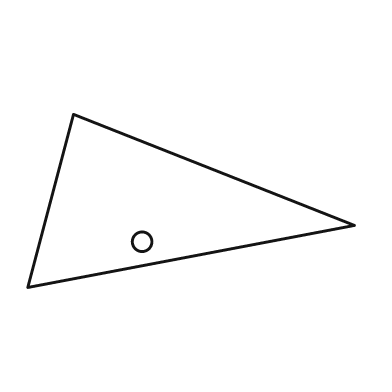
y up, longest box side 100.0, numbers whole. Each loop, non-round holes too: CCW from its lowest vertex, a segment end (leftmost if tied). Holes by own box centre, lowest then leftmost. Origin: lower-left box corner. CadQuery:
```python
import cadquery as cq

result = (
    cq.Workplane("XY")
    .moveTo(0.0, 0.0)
    .lineTo(100.0, 19.0)
    .lineTo(14.0, 53.0)
    .close()
    .moveTo(35.0, 14.0)
    .circle(3.0)
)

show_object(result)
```